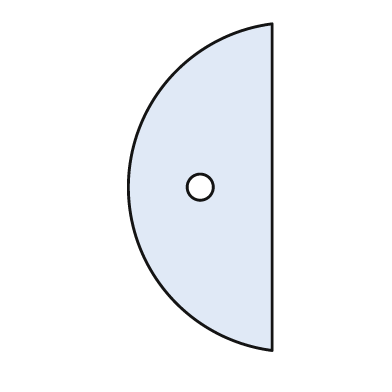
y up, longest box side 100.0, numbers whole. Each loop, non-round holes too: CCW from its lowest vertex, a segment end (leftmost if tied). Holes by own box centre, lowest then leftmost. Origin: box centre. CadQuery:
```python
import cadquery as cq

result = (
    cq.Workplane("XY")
    .moveTo(22.0, -50.0)
    .lineTo(22.0, 50.0)
    .threePointArc((-22.0, 0.0), (22.0, -50.0))
    .close()
    .moveTo(0.0, 0.0)
    .circle(4.0)
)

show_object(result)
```